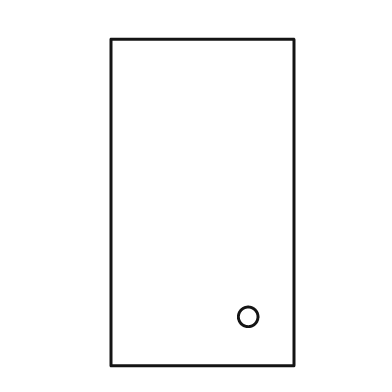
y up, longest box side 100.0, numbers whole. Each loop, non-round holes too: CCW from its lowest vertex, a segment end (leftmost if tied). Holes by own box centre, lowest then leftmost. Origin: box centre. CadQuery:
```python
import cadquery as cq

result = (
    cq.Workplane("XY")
    .moveTo(-28.0, -50.0)
    .lineTo(28.0, -50.0)
    .lineTo(28.0, 50.0)
    .lineTo(-28.0, 50.0)
    .close()
    .moveTo(14.0, -35.0)
    .circle(3.0)
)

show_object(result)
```